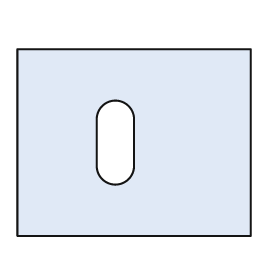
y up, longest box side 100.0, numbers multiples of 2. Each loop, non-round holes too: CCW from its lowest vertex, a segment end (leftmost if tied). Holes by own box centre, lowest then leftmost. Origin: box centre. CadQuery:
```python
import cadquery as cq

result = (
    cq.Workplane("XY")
    .moveTo(-50.0, -40.0)
    .lineTo(50.0, -40.0)
    .lineTo(50.0, 40.0)
    .lineTo(-50.0, 40.0)
    .close()
    .moveTo(-16.0, -10.0)
    .threePointArc((-8.0, -18.0), (0.0, -10.0))
    .lineTo(0.0, 10.0)
    .threePointArc((-8.0, 18.0), (-16.0, 10.0))
    .close()
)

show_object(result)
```